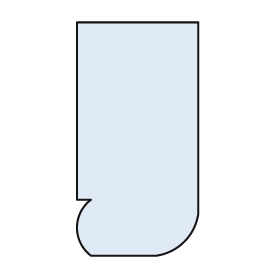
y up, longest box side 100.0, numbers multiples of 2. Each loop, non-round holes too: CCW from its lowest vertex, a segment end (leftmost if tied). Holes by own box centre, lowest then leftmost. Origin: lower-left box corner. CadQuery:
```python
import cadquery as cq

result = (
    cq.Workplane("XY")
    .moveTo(6.0, 0.0)
    .lineTo(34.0, 0.0)
    .threePointArc((46.0, 6.0), (52.0, 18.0))
    .lineTo(52.0, 100.0)
    .lineTo(0.0, 100.0)
    .lineTo(0.0, 24.0)
    .lineTo(6.0, 24.0)
    .threePointArc((0.0, 12.0), (6.0, 0.0))
    .close()
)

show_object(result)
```